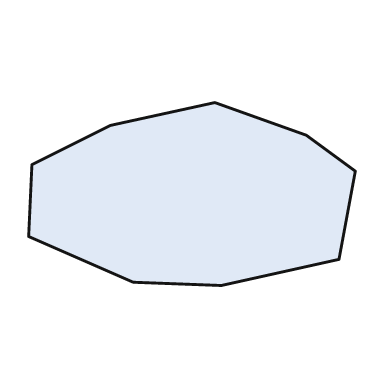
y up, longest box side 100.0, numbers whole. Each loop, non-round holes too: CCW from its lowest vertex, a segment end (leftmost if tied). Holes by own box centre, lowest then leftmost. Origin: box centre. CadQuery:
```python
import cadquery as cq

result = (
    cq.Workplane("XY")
    .moveTo(9.0, -28.0)
    .lineTo(45.0, -20.0)
    .lineTo(50.0, 7.0)
    .lineTo(35.0, 18.0)
    .lineTo(7.0, 28.0)
    .lineTo(-25.0, 21.0)
    .lineTo(-49.0, 9.0)
    .lineTo(-50.0, -13.0)
    .lineTo(-18.0, -27.0)
    .close()
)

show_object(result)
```